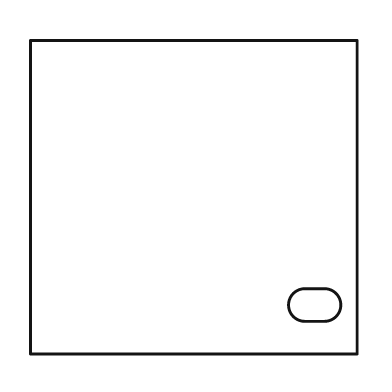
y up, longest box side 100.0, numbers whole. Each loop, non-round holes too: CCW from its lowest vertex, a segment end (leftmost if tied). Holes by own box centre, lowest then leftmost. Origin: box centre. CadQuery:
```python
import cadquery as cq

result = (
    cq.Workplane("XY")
    .moveTo(-50.0, -48.0)
    .lineTo(50.0, -48.0)
    .lineTo(50.0, 48.0)
    .lineTo(-50.0, 48.0)
    .close()
    .moveTo(34.0, -38.0)
    .lineTo(40.0, -38.0)
    .threePointArc((45.0, -33.0), (40.0, -28.0))
    .lineTo(34.0, -28.0)
    .threePointArc((29.0, -33.0), (34.0, -38.0))
    .close()
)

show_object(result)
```